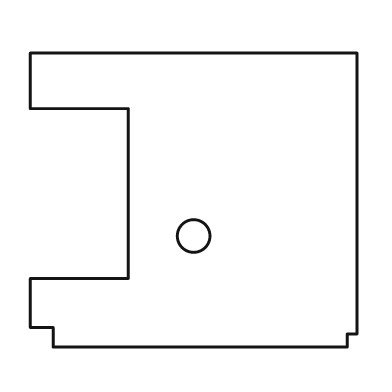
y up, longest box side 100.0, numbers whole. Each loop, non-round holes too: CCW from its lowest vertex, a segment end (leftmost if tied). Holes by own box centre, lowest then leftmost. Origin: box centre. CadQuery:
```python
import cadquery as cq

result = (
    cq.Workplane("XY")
    .moveTo(-43.0, -45.0)
    .lineTo(47.0, -45.0)
    .lineTo(47.0, -41.0)
    .lineTo(50.0, -41.0)
    .lineTo(50.0, 45.0)
    .lineTo(-50.0, 45.0)
    .lineTo(-50.0, 28.0)
    .lineTo(-20.0, 28.0)
    .lineTo(-20.0, -24.0)
    .lineTo(-50.0, -24.0)
    .lineTo(-50.0, -39.0)
    .lineTo(-43.0, -39.0)
    .close()
    .moveTo(0.0, -11.0)
    .circle(5.0)
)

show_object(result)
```